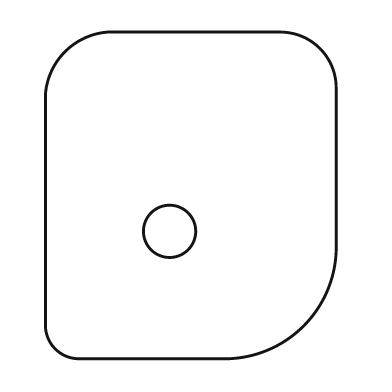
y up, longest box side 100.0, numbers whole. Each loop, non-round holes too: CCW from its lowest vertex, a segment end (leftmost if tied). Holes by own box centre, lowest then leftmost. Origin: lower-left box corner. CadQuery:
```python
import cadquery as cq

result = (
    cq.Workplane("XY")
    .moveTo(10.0, 0.0)
    .lineTo(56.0, 0.0)
    .threePointArc((79.0, 10.0), (89.0, 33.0))
    .lineTo(89.0, 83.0)
    .threePointArc((84.0, 95.0), (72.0, 100.0))
    .lineTo(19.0, 100.0)
    .threePointArc((6.0, 94.0), (0.0, 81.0))
    .lineTo(0.0, 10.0)
    .threePointArc((3.0, 3.0), (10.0, 0.0))
    .close()
    .moveTo(38.0, 39.0)
    .circle(8.0)
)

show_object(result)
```